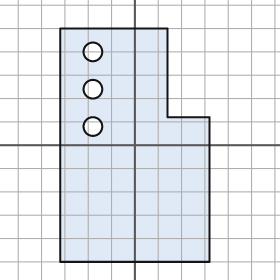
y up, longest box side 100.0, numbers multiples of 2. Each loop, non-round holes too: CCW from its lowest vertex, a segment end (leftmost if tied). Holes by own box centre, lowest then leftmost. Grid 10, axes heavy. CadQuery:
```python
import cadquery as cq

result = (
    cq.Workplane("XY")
    .moveTo(-32.0, -50.0)
    .lineTo(32.0, -50.0)
    .lineTo(32.0, 12.0)
    .lineTo(14.0, 12.0)
    .lineTo(14.0, 50.0)
    .lineTo(-32.0, 50.0)
    .close()
    .moveTo(-18.0, 8.0)
    .circle(4.0)
    .moveTo(-18.0, 24.0)
    .circle(4.0)
    .moveTo(-18.0, 40.0)
    .circle(4.0)
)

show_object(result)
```